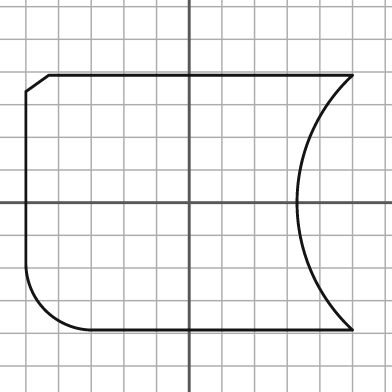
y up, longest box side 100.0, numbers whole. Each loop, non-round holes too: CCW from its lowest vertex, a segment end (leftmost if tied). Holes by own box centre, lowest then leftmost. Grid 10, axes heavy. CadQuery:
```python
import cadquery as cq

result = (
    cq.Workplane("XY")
    .moveTo(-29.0, -39.0)
    .lineTo(50.0, -39.0)
    .threePointArc((33.0, 0.0), (50.0, 39.0))
    .lineTo(-43.0, 39.0)
    .lineTo(-50.0, 34.0)
    .lineTo(-50.0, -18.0)
    .threePointArc((-44.0, -33.0), (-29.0, -39.0))
    .close()
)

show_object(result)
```